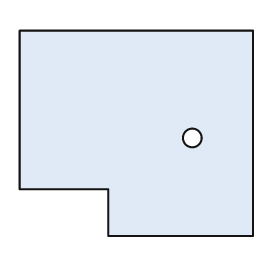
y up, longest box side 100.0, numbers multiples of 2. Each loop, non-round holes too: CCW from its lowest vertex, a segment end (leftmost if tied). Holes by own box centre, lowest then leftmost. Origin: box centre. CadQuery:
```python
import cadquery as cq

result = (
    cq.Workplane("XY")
    .moveTo(-12.0, -44.0)
    .lineTo(50.0, -44.0)
    .lineTo(50.0, 44.0)
    .lineTo(-50.0, 44.0)
    .lineTo(-50.0, -24.0)
    .lineTo(-12.0, -24.0)
    .close()
    .moveTo(24.0, -2.0)
    .circle(4.0)
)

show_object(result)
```